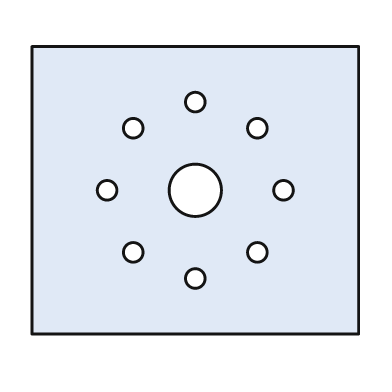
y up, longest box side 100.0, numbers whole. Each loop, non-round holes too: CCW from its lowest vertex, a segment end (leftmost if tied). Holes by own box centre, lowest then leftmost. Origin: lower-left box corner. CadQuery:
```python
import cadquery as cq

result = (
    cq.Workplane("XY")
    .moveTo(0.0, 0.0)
    .lineTo(100.0, 0.0)
    .lineTo(100.0, 88.0)
    .lineTo(0.0, 88.0)
    .close()
    .moveTo(50.0, 17.0)
    .circle(3.0)
    .moveTo(31.0, 25.0)
    .circle(3.0)
    .moveTo(69.0, 25.0)
    .circle(3.0)
    .moveTo(23.0, 44.0)
    .circle(3.0)
    .moveTo(50.0, 44.0)
    .circle(8.0)
    .moveTo(77.0, 44.0)
    .circle(3.0)
    .moveTo(31.0, 63.0)
    .circle(3.0)
    .moveTo(69.0, 63.0)
    .circle(3.0)
    .moveTo(50.0, 71.0)
    .circle(3.0)
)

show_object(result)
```